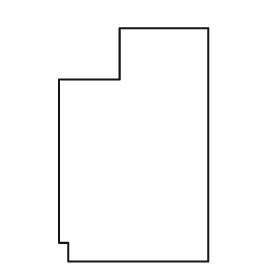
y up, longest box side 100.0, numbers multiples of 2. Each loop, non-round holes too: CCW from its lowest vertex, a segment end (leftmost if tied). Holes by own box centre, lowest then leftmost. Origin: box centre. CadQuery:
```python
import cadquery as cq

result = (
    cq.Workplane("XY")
    .moveTo(-28.0, -50.0)
    .lineTo(32.0, -50.0)
    .lineTo(32.0, 50.0)
    .lineTo(-6.0, 50.0)
    .lineTo(-6.0, 28.0)
    .lineTo(-32.0, 28.0)
    .lineTo(-32.0, -42.0)
    .lineTo(-28.0, -42.0)
    .close()
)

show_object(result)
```